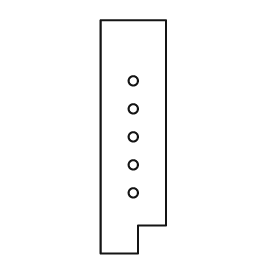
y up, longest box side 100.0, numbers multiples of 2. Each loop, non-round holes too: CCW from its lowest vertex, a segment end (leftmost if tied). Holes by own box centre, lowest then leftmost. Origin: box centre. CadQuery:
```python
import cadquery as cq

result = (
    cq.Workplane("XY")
    .moveTo(-14.0, -50.0)
    .lineTo(2.0, -50.0)
    .lineTo(2.0, -38.0)
    .lineTo(14.0, -38.0)
    .lineTo(14.0, 50.0)
    .lineTo(-14.0, 50.0)
    .close()
    .moveTo(0.0, -24.0)
    .circle(2.0)
    .moveTo(0.0, -12.0)
    .circle(2.0)
    .moveTo(0.0, 0.0)
    .circle(2.0)
    .moveTo(0.0, 12.0)
    .circle(2.0)
    .moveTo(0.0, 24.0)
    .circle(2.0)
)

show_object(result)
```